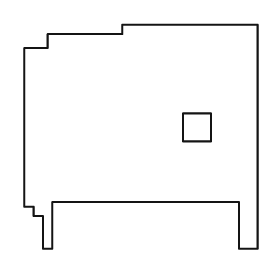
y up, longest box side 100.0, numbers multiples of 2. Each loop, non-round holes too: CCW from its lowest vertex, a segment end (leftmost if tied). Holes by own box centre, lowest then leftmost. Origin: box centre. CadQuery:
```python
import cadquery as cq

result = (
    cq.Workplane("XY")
    .moveTo(-42.0, -48.0)
    .lineTo(-38.0, -48.0)
    .lineTo(-38.0, -28.0)
    .lineTo(42.0, -28.0)
    .lineTo(42.0, -48.0)
    .lineTo(50.0, -48.0)
    .lineTo(50.0, 48.0)
    .lineTo(-8.0, 48.0)
    .lineTo(-8.0, 44.0)
    .lineTo(-40.0, 44.0)
    .lineTo(-40.0, 38.0)
    .lineTo(-50.0, 38.0)
    .lineTo(-50.0, -30.0)
    .lineTo(-46.0, -30.0)
    .lineTo(-46.0, -34.0)
    .lineTo(-42.0, -34.0)
    .close()
    .moveTo(18.0, -2.0)
    .lineTo(30.0, -2.0)
    .lineTo(30.0, 10.0)
    .lineTo(18.0, 10.0)
    .close()
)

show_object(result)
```